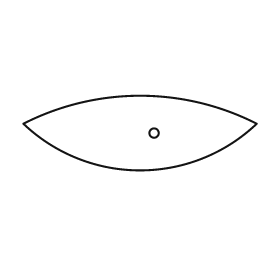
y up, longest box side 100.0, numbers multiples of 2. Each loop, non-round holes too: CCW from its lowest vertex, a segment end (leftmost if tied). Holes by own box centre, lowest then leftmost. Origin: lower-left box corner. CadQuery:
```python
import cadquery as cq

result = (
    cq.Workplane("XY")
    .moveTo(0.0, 20.0)
    .threePointArc((50.0, 0.0), (100.0, 20.0))
    .threePointArc((50.0, 32.0), (0.0, 20.0))
    .close()
    .moveTo(56.0, 16.0)
    .circle(2.0)
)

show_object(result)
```